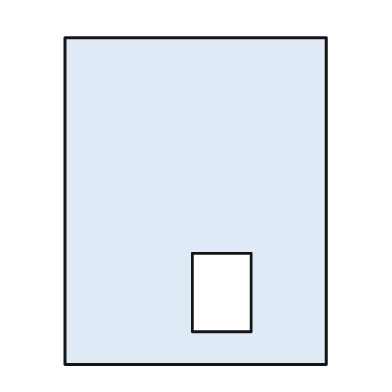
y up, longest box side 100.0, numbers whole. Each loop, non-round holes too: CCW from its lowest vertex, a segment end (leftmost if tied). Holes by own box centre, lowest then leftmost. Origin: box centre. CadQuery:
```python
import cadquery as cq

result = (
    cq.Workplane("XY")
    .moveTo(-40.0, -50.0)
    .lineTo(40.0, -50.0)
    .lineTo(40.0, 50.0)
    .lineTo(-40.0, 50.0)
    .close()
    .moveTo(-1.0, -40.0)
    .lineTo(17.0, -40.0)
    .lineTo(17.0, -16.0)
    .lineTo(-1.0, -16.0)
    .close()
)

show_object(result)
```